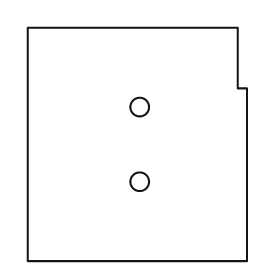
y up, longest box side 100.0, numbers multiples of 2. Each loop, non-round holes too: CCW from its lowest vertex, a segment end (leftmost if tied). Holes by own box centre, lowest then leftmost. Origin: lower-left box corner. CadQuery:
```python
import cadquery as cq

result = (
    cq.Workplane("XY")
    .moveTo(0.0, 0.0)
    .lineTo(94.0, 0.0)
    .lineTo(94.0, 74.0)
    .lineTo(90.0, 74.0)
    .lineTo(90.0, 100.0)
    .lineTo(0.0, 100.0)
    .close()
    .moveTo(48.0, 34.0)
    .circle(4.0)
    .moveTo(48.0, 66.0)
    .circle(4.0)
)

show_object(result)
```